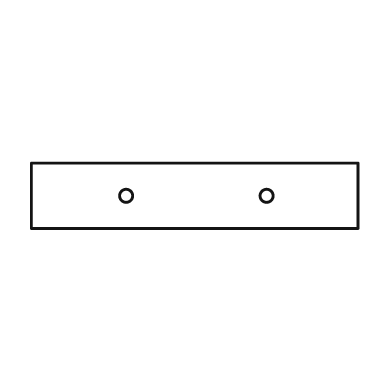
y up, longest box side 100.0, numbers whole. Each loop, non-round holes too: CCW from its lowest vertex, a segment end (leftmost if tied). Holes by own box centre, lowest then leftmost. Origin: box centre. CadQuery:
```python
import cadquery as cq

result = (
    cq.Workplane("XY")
    .moveTo(-50.0, -10.0)
    .lineTo(50.0, -10.0)
    .lineTo(50.0, 10.0)
    .lineTo(-50.0, 10.0)
    .close()
    .moveTo(-21.0, 0.0)
    .circle(2.0)
    .moveTo(22.0, 0.0)
    .circle(2.0)
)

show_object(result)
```